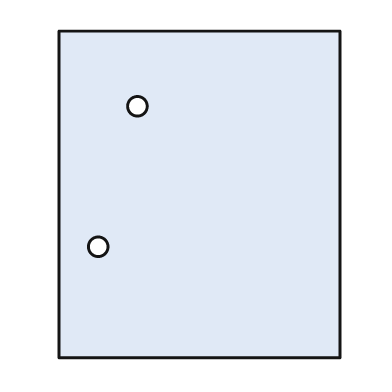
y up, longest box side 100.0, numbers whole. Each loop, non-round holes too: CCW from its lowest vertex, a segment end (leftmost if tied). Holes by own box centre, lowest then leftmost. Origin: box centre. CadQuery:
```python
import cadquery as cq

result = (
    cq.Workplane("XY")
    .moveTo(-43.0, -50.0)
    .lineTo(43.0, -50.0)
    .lineTo(43.0, 50.0)
    .lineTo(-43.0, 50.0)
    .close()
    .moveTo(-31.0, -16.0)
    .circle(3.0)
    .moveTo(-19.0, 27.0)
    .circle(3.0)
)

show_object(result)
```